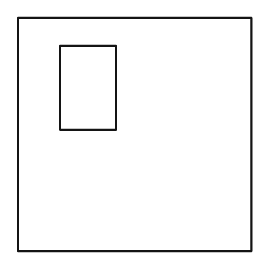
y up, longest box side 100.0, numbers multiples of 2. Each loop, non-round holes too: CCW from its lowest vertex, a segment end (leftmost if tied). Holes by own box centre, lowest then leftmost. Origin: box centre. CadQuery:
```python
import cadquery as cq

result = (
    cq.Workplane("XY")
    .moveTo(-50.0, -50.0)
    .lineTo(50.0, -50.0)
    .lineTo(50.0, 50.0)
    .lineTo(-50.0, 50.0)
    .close()
    .moveTo(-32.0, 2.0)
    .lineTo(-8.0, 2.0)
    .lineTo(-8.0, 38.0)
    .lineTo(-32.0, 38.0)
    .close()
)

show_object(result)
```